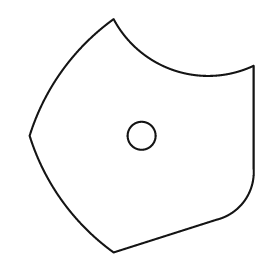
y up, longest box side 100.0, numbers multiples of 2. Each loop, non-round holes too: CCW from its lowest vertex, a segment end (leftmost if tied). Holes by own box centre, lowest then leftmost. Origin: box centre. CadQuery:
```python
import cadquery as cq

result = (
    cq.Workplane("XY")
    .moveTo(-12.0, -50.0)
    .lineTo(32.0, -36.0)
    .threePointArc((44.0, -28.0), (48.0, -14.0))
    .lineTo(48.0, 30.0)
    .threePointArc((14.0, 28.0), (-12.0, 50.0))
    .threePointArc((-34.0, 28.0), (-48.0, 0.0))
    .threePointArc((-34.0, -28.0), (-12.0, -50.0))
    .close()
    .moveTo(0.0, 0.0)
    .circle(6.0)
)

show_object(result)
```